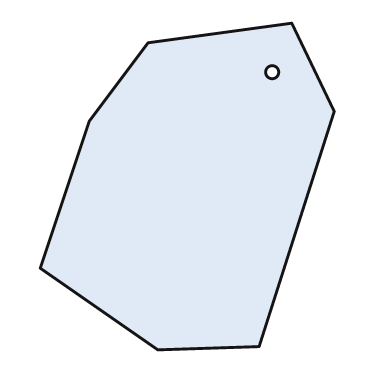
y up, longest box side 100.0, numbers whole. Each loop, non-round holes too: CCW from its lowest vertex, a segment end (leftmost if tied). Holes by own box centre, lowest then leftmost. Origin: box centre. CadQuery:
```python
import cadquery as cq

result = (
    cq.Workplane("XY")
    .moveTo(-9.0, -50.0)
    .lineTo(22.0, -49.0)
    .lineTo(45.0, 23.0)
    .lineTo(32.0, 50.0)
    .lineTo(-12.0, 44.0)
    .lineTo(-30.0, 20.0)
    .lineTo(-45.0, -25.0)
    .close()
    .moveTo(26.0, 35.0)
    .circle(2.0)
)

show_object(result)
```